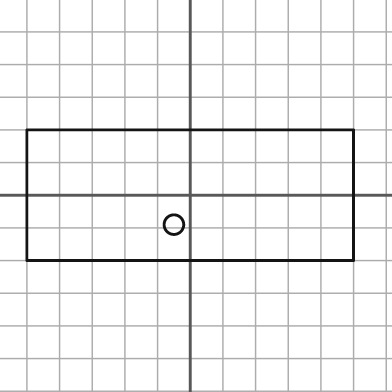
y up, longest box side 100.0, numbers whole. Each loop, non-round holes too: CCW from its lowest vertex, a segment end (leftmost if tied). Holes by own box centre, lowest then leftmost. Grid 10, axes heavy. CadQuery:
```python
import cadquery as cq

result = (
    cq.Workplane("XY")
    .moveTo(-50.0, -20.0)
    .lineTo(50.0, -20.0)
    .lineTo(50.0, 20.0)
    .lineTo(-50.0, 20.0)
    .close()
    .moveTo(-5.0, -9.0)
    .circle(3.0)
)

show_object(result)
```